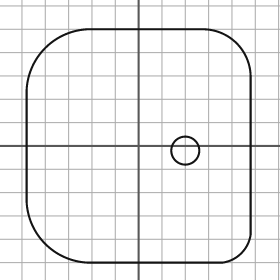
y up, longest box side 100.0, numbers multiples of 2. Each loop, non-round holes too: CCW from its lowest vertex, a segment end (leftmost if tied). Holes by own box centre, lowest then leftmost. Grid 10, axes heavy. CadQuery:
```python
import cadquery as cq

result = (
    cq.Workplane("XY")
    .moveTo(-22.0, -50.0)
    .lineTo(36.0, -50.0)
    .threePointArc((44.0, -46.0), (48.0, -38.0))
    .lineTo(48.0, 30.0)
    .threePointArc((42.0, 44.0), (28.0, 50.0))
    .lineTo(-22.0, 50.0)
    .threePointArc((-40.0, 42.0), (-48.0, 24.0))
    .lineTo(-48.0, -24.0)
    .threePointArc((-40.0, -42.0), (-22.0, -50.0))
    .close()
    .moveTo(20.0, -2.0)
    .circle(6.0)
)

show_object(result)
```